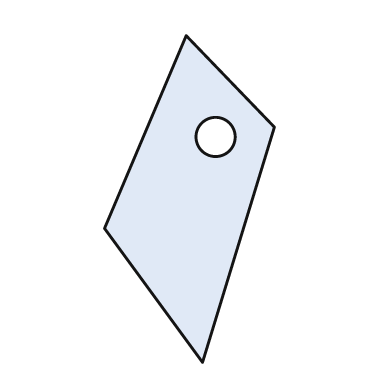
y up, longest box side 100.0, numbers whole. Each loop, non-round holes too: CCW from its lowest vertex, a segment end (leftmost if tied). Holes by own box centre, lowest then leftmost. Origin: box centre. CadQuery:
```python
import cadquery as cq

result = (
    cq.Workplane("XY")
    .moveTo(4.0, -50.0)
    .lineTo(26.0, 22.0)
    .lineTo(-1.0, 50.0)
    .lineTo(-26.0, -9.0)
    .close()
    .moveTo(8.0, 19.0)
    .circle(6.0)
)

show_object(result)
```